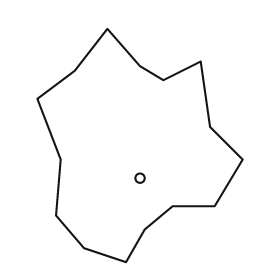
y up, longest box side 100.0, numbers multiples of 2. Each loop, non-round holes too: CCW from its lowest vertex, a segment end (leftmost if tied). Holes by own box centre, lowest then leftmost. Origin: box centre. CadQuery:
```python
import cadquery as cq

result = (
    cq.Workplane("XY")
    .moveTo(-6.0, -50.0)
    .lineTo(2.0, -36.0)
    .lineTo(14.0, -26.0)
    .lineTo(32.0, -26.0)
    .lineTo(44.0, -6.0)
    .lineTo(30.0, 8.0)
    .lineTo(26.0, 36.0)
    .lineTo(10.0, 28.0)
    .lineTo(0.0, 34.0)
    .lineTo(-14.0, 50.0)
    .lineTo(-28.0, 32.0)
    .lineTo(-44.0, 20.0)
    .lineTo(-34.0, -6.0)
    .lineTo(-36.0, -30.0)
    .lineTo(-24.0, -44.0)
    .close()
    .moveTo(0.0, -14.0)
    .circle(2.0)
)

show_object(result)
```